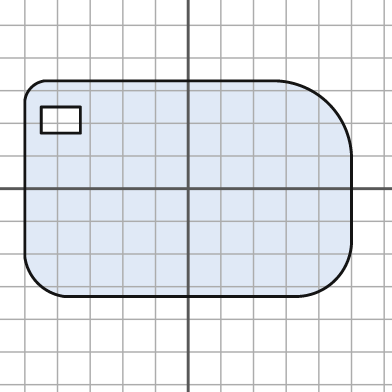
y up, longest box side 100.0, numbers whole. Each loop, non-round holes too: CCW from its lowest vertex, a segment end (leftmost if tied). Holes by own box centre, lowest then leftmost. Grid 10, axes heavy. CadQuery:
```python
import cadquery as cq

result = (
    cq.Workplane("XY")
    .moveTo(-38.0, -33.0)
    .lineTo(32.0, -33.0)
    .threePointArc((45.0, -28.0), (50.0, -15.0))
    .lineTo(50.0, 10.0)
    .threePointArc((43.0, 26.0), (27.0, 33.0))
    .lineTo(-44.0, 33.0)
    .threePointArc((-48.0, 31.0), (-50.0, 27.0))
    .lineTo(-50.0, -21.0)
    .threePointArc((-46.0, -29.0), (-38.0, -33.0))
    .close()
    .moveTo(-45.0, 17.0)
    .lineTo(-33.0, 17.0)
    .lineTo(-33.0, 25.0)
    .lineTo(-45.0, 25.0)
    .close()
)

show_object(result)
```